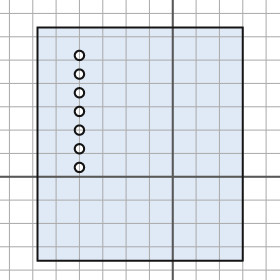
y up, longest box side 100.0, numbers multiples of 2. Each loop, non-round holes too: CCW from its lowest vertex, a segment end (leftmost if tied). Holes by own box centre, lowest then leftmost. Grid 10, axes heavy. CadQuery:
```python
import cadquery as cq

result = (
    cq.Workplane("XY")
    .moveTo(-58.0, -36.0)
    .lineTo(30.0, -36.0)
    .lineTo(30.0, 64.0)
    .lineTo(-58.0, 64.0)
    .close()
    .moveTo(-40.0, 4.0)
    .circle(2.0)
    .moveTo(-40.0, 12.0)
    .circle(2.0)
    .moveTo(-40.0, 20.0)
    .circle(2.0)
    .moveTo(-40.0, 28.0)
    .circle(2.0)
    .moveTo(-40.0, 36.0)
    .circle(2.0)
    .moveTo(-40.0, 44.0)
    .circle(2.0)
    .moveTo(-40.0, 52.0)
    .circle(2.0)
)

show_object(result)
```